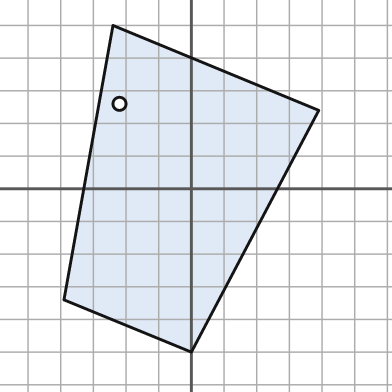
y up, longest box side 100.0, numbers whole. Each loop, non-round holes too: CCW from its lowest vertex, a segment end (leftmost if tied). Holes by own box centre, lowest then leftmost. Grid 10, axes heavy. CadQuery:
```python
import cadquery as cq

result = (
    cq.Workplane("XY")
    .moveTo(0.0, -50.0)
    .lineTo(39.0, 24.0)
    .lineTo(-24.0, 50.0)
    .lineTo(-39.0, -34.0)
    .close()
    .moveTo(-22.0, 26.0)
    .circle(2.0)
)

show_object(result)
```